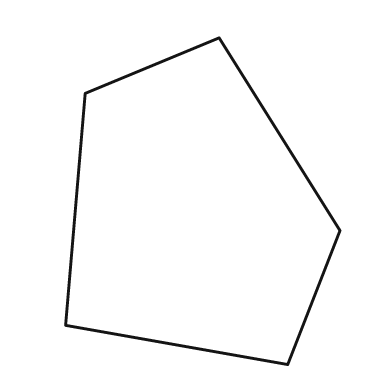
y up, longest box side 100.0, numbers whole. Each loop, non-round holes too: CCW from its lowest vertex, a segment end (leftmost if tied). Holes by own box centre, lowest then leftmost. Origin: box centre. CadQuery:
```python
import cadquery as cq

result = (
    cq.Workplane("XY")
    .moveTo(26.0, -50.0)
    .lineTo(42.0, -9.0)
    .lineTo(5.0, 50.0)
    .lineTo(-36.0, 33.0)
    .lineTo(-42.0, -38.0)
    .close()
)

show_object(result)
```